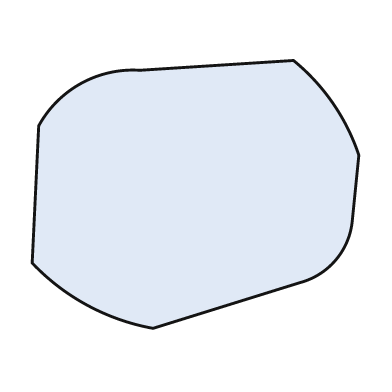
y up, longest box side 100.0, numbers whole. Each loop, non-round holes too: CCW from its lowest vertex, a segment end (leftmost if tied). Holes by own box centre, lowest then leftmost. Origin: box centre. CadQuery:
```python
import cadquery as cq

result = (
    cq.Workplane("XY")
    .moveTo(-13.0, -41.0)
    .lineTo(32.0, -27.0)
    .threePointArc((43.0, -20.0), (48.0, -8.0))
    .lineTo(50.0, 12.0)
    .threePointArc((42.0, 28.0), (30.0, 41.0))
    .lineTo(-17.0, 38.0)
    .threePointArc((-35.0, 34.0), (-48.0, 21.0))
    .lineTo(-50.0, -21.0)
    .threePointArc((-33.0, -34.0), (-13.0, -41.0))
    .close()
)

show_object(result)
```